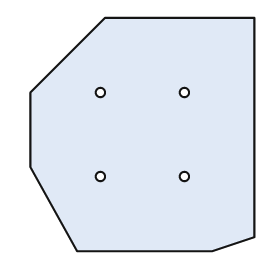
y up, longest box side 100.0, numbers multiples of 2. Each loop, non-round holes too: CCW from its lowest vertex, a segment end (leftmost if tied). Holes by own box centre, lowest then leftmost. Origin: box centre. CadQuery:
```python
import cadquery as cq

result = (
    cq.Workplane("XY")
    .moveTo(-28.0, -50.0)
    .lineTo(30.0, -50.0)
    .lineTo(48.0, -44.0)
    .lineTo(48.0, 50.0)
    .lineTo(-16.0, 50.0)
    .lineTo(-48.0, 18.0)
    .lineTo(-48.0, -14.0)
    .close()
    .moveTo(-18.0, -18.0)
    .circle(2.0)
    .moveTo(18.0, -18.0)
    .circle(2.0)
    .moveTo(-18.0, 18.0)
    .circle(2.0)
    .moveTo(18.0, 18.0)
    .circle(2.0)
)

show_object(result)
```